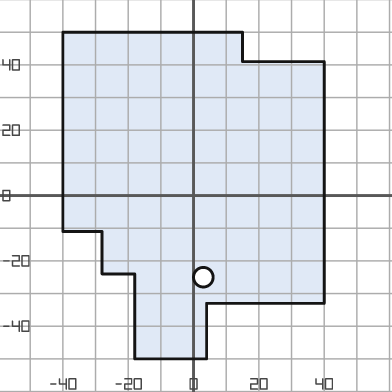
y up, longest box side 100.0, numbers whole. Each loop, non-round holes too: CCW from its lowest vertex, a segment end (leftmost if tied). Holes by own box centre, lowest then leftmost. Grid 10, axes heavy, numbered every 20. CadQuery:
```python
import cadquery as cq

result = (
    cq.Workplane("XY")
    .moveTo(-18.0, -50.0)
    .lineTo(4.0, -50.0)
    .lineTo(4.0, -33.0)
    .lineTo(40.0, -33.0)
    .lineTo(40.0, 41.0)
    .lineTo(15.0, 41.0)
    .lineTo(15.0, 50.0)
    .lineTo(-40.0, 50.0)
    .lineTo(-40.0, -11.0)
    .lineTo(-28.0, -11.0)
    .lineTo(-28.0, -24.0)
    .lineTo(-18.0, -24.0)
    .close()
    .moveTo(3.0, -25.0)
    .circle(3.0)
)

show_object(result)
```